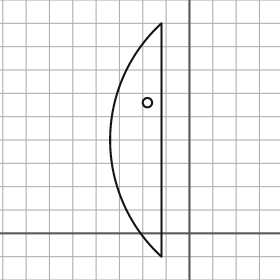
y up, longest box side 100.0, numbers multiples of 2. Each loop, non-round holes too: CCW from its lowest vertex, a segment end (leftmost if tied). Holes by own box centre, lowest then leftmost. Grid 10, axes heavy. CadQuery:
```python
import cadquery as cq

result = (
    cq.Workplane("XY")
    .moveTo(-12.0, -10.0)
    .lineTo(-12.0, 90.0)
    .threePointArc((-34.0, 40.0), (-12.0, -10.0))
    .close()
    .moveTo(-18.0, 56.0)
    .circle(2.0)
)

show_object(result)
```